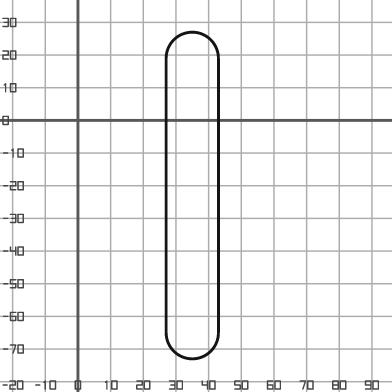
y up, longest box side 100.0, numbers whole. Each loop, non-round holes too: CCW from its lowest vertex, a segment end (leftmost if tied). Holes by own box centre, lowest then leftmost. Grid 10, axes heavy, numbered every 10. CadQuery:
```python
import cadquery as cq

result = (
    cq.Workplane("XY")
    .moveTo(27.0, -65.0)
    .threePointArc((35.0, -73.0), (43.0, -65.0))
    .lineTo(43.0, 19.0)
    .threePointArc((35.0, 27.0), (27.0, 19.0))
    .close()
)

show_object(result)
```